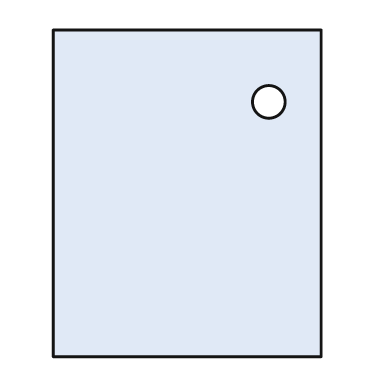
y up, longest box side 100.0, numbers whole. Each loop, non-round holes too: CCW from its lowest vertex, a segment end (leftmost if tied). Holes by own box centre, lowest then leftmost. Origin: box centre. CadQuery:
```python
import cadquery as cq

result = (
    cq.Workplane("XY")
    .moveTo(-41.0, -50.0)
    .lineTo(41.0, -50.0)
    .lineTo(41.0, 50.0)
    .lineTo(-41.0, 50.0)
    .close()
    .moveTo(25.0, 28.0)
    .circle(5.0)
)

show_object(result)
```